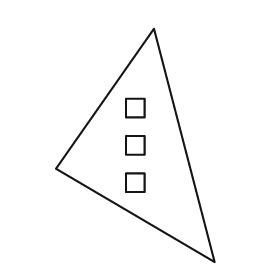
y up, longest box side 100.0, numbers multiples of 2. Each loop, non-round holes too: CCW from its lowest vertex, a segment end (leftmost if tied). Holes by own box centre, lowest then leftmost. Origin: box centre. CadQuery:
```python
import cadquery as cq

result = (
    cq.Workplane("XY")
    .moveTo(34.0, -50.0)
    .lineTo(8.0, 50.0)
    .lineTo(-34.0, -10.0)
    .close()
    .moveTo(-4.0, -20.0)
    .lineTo(4.0, -20.0)
    .lineTo(4.0, -12.0)
    .lineTo(-4.0, -12.0)
    .close()
    .moveTo(-4.0, -4.0)
    .lineTo(4.0, -4.0)
    .lineTo(4.0, 4.0)
    .lineTo(-4.0, 4.0)
    .close()
    .moveTo(-4.0, 12.0)
    .lineTo(4.0, 12.0)
    .lineTo(4.0, 20.0)
    .lineTo(-4.0, 20.0)
    .close()
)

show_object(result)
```